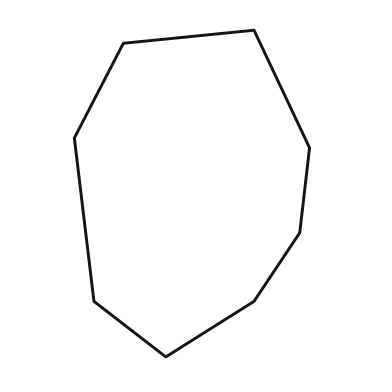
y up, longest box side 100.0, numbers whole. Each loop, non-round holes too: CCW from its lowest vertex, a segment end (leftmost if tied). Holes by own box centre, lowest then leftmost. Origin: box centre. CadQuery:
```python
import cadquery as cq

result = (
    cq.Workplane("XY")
    .moveTo(-8.0, -50.0)
    .lineTo(19.0, -33.0)
    .lineTo(33.0, -12.0)
    .lineTo(36.0, 14.0)
    .lineTo(19.0, 50.0)
    .lineTo(-21.0, 46.0)
    .lineTo(-36.0, 17.0)
    .lineTo(-30.0, -33.0)
    .close()
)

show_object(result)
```